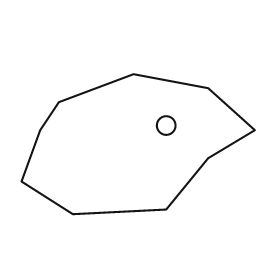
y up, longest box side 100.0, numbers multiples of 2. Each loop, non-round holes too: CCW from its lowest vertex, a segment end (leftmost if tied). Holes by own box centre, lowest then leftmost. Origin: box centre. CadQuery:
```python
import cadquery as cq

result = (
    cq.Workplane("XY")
    .moveTo(-28.0, -30.0)
    .lineTo(12.0, -28.0)
    .lineTo(30.0, -6.0)
    .lineTo(50.0, 6.0)
    .lineTo(30.0, 24.0)
    .lineTo(-2.0, 30.0)
    .lineTo(-34.0, 18.0)
    .lineTo(-42.0, 6.0)
    .lineTo(-50.0, -16.0)
    .close()
    .moveTo(12.0, 8.0)
    .circle(4.0)
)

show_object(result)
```